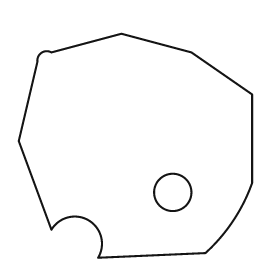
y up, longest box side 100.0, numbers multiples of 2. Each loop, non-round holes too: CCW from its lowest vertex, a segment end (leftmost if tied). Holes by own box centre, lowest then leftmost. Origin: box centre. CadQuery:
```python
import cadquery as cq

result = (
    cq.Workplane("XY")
    .moveTo(-16.0, -48.0)
    .lineTo(30.0, -46.0)
    .threePointArc((42.0, -32.0), (50.0, -16.0))
    .lineTo(50.0, 22.0)
    .lineTo(24.0, 40.0)
    .lineTo(-6.0, 48.0)
    .lineTo(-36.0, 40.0)
    .threePointArc((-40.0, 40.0), (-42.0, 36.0))
    .lineTo(-50.0, 2.0)
    .lineTo(-36.0, -36.0)
    .threePointArc((-20.0, -32.0), (-16.0, -48.0))
    .close()
    .moveTo(16.0, -20.0)
    .circle(8.0)
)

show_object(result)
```